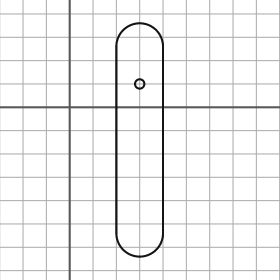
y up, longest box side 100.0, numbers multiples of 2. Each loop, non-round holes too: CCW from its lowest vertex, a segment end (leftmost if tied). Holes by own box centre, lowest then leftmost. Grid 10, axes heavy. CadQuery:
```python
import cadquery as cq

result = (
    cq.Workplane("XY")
    .moveTo(20.0, -54.0)
    .threePointArc((30.0, -64.0), (40.0, -54.0))
    .lineTo(40.0, 26.0)
    .threePointArc((30.0, 36.0), (20.0, 26.0))
    .close()
    .moveTo(30.0, 10.0)
    .circle(2.0)
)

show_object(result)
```